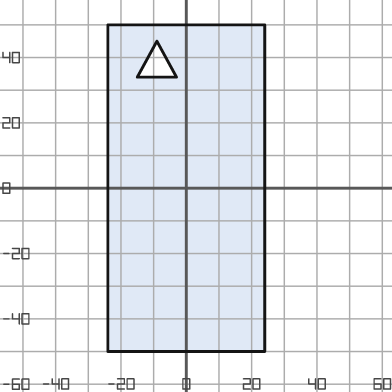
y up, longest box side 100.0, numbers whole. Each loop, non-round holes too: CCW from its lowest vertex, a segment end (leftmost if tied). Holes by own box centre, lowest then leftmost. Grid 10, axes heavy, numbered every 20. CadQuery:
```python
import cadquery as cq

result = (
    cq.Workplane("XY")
    .moveTo(-24.0, -50.0)
    .lineTo(24.0, -50.0)
    .lineTo(24.0, 50.0)
    .lineTo(-24.0, 50.0)
    .close()
    .moveTo(-15.0, 34.0)
    .lineTo(-3.0, 34.0)
    .lineTo(-9.0, 45.0)
    .close()
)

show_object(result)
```